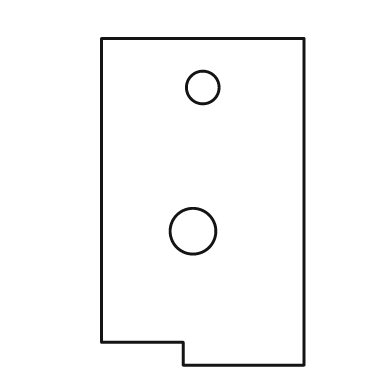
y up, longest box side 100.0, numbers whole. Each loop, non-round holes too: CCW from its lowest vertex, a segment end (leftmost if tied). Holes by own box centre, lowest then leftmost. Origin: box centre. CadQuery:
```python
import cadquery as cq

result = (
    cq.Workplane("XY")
    .moveTo(-6.0, -50.0)
    .lineTo(31.0, -50.0)
    .lineTo(31.0, 50.0)
    .lineTo(-31.0, 50.0)
    .lineTo(-31.0, -43.0)
    .lineTo(-6.0, -43.0)
    .close()
    .moveTo(-3.0, -9.0)
    .circle(7.0)
    .moveTo(0.0, 35.0)
    .circle(5.0)
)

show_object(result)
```